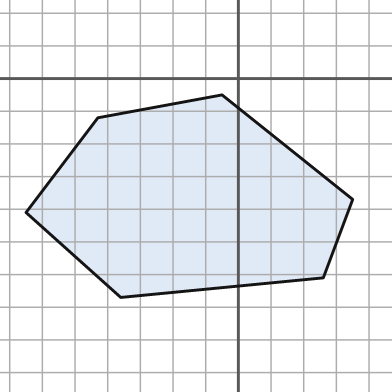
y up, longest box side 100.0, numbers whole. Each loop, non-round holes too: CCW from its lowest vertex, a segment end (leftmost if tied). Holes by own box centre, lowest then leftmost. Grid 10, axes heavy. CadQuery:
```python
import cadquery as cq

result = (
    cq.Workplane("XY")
    .moveTo(-36.0, -67.0)
    .lineTo(26.0, -61.0)
    .lineTo(35.0, -37.0)
    .lineTo(-5.0, -5.0)
    .lineTo(-43.0, -12.0)
    .lineTo(-65.0, -41.0)
    .close()
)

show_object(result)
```